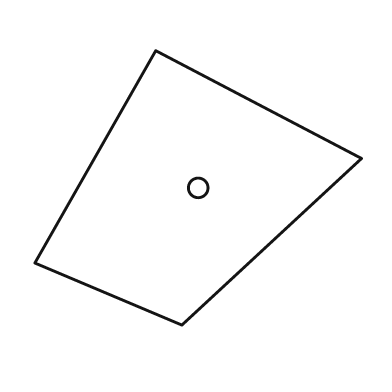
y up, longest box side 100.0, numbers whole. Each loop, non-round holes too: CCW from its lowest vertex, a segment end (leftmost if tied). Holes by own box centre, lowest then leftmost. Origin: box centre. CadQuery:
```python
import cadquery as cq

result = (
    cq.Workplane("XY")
    .moveTo(-5.0, -42.0)
    .lineTo(50.0, 9.0)
    .lineTo(-13.0, 42.0)
    .lineTo(-50.0, -23.0)
    .close()
    .moveTo(0.0, 0.0)
    .circle(3.0)
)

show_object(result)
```